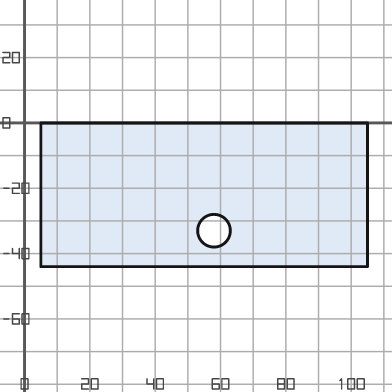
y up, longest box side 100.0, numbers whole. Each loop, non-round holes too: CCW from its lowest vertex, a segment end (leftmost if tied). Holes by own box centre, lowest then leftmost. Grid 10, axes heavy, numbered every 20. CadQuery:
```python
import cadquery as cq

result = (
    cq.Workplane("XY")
    .moveTo(5.0, -44.0)
    .lineTo(105.0, -44.0)
    .lineTo(105.0, 0.0)
    .lineTo(5.0, 0.0)
    .close()
    .moveTo(58.0, -33.0)
    .circle(5.0)
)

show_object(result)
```